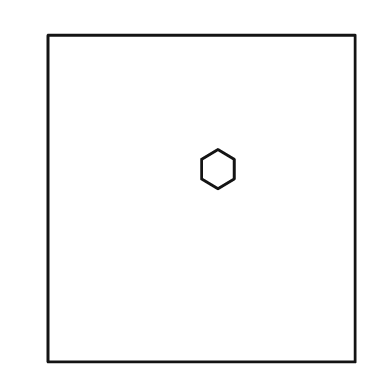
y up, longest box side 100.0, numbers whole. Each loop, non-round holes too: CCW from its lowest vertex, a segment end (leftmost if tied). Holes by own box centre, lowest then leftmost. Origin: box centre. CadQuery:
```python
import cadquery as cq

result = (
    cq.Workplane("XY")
    .moveTo(-47.0, -50.0)
    .lineTo(47.0, -50.0)
    .lineTo(47.0, 50.0)
    .lineTo(-47.0, 50.0)
    .close()
    .moveTo(5.0, 3.0)
    .lineTo(10.0, 6.0)
    .lineTo(10.0, 12.0)
    .lineTo(5.0, 15.0)
    .lineTo(0.0, 12.0)
    .lineTo(0.0, 6.0)
    .close()
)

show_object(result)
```